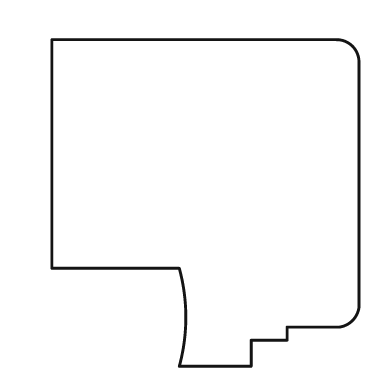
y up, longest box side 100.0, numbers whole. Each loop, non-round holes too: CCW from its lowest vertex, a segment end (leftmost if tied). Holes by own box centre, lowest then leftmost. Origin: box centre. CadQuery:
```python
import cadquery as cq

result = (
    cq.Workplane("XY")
    .moveTo(-8.0, -50.0)
    .lineTo(14.0, -50.0)
    .lineTo(14.0, -42.0)
    .lineTo(25.0, -42.0)
    .lineTo(25.0, -38.0)
    .lineTo(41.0, -38.0)
    .threePointArc((45.0, -36.0), (47.0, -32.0))
    .lineTo(47.0, 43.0)
    .threePointArc((45.0, 48.0), (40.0, 50.0))
    .lineTo(-47.0, 50.0)
    .lineTo(-47.0, -20.0)
    .lineTo(-8.0, -20.0)
    .threePointArc((-6.0, -35.0), (-8.0, -50.0))
    .close()
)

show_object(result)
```